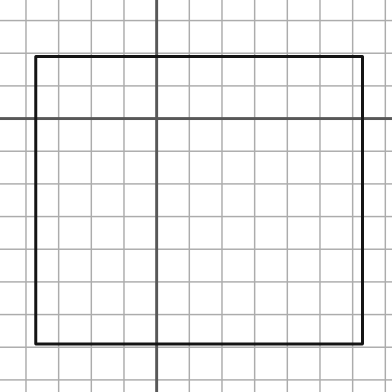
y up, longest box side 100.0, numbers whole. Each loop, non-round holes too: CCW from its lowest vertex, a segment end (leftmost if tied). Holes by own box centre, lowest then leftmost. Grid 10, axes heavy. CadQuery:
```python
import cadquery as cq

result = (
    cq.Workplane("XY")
    .moveTo(-37.0, -69.0)
    .lineTo(63.0, -69.0)
    .lineTo(63.0, 19.0)
    .lineTo(-37.0, 19.0)
    .close()
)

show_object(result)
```